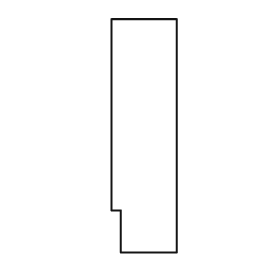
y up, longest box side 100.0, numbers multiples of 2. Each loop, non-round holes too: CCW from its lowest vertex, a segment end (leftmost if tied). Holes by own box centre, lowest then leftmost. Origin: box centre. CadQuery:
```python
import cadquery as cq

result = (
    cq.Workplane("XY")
    .moveTo(-10.0, -50.0)
    .lineTo(14.0, -50.0)
    .lineTo(14.0, 50.0)
    .lineTo(-14.0, 50.0)
    .lineTo(-14.0, -32.0)
    .lineTo(-10.0, -32.0)
    .close()
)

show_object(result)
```